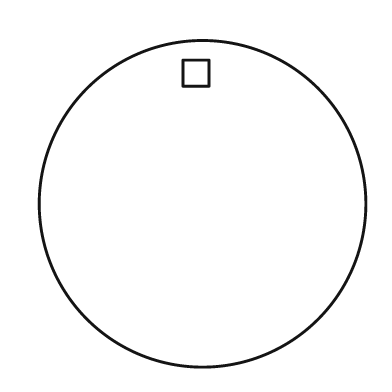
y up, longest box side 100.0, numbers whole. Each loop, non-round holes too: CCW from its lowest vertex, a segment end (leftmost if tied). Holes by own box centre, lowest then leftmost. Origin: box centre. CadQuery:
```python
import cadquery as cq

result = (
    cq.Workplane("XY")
    .moveTo(0.0, 0.0)
    .circle(50.0)
    .moveTo(-6.0, 36.0)
    .lineTo(2.0, 36.0)
    .lineTo(2.0, 44.0)
    .lineTo(-6.0, 44.0)
    .close()
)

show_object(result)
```